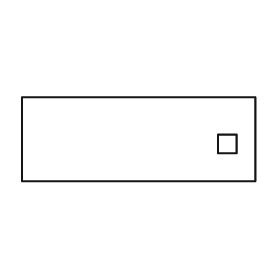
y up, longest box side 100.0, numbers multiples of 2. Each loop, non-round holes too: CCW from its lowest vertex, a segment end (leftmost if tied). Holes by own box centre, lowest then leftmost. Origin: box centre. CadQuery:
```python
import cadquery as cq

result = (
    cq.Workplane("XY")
    .moveTo(-50.0, -18.0)
    .lineTo(50.0, -18.0)
    .lineTo(50.0, 18.0)
    .lineTo(-50.0, 18.0)
    .close()
    .moveTo(34.0, -6.0)
    .lineTo(42.0, -6.0)
    .lineTo(42.0, 2.0)
    .lineTo(34.0, 2.0)
    .close()
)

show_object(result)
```